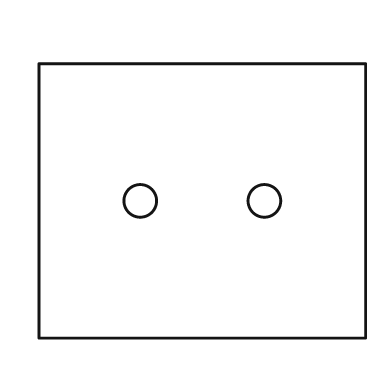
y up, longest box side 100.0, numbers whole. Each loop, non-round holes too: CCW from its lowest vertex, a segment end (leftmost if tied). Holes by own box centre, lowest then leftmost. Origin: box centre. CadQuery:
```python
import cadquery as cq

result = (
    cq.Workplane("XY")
    .moveTo(-50.0, -42.0)
    .lineTo(50.0, -42.0)
    .lineTo(50.0, 42.0)
    .lineTo(-50.0, 42.0)
    .close()
    .moveTo(-19.0, 0.0)
    .circle(5.0)
    .moveTo(19.0, 0.0)
    .circle(5.0)
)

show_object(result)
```